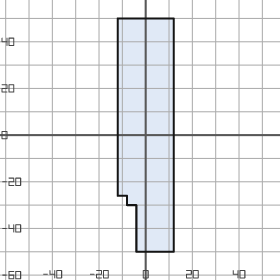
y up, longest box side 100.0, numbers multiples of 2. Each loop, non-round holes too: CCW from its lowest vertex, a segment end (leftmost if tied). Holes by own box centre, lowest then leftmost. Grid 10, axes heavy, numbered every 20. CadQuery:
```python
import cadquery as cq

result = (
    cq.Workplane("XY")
    .moveTo(-4.0, -50.0)
    .lineTo(12.0, -50.0)
    .lineTo(12.0, 50.0)
    .lineTo(-12.0, 50.0)
    .lineTo(-12.0, -26.0)
    .lineTo(-8.0, -26.0)
    .lineTo(-8.0, -30.0)
    .lineTo(-4.0, -30.0)
    .close()
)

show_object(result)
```